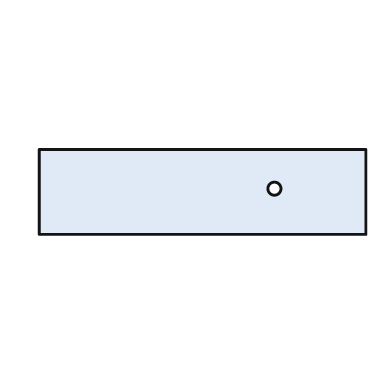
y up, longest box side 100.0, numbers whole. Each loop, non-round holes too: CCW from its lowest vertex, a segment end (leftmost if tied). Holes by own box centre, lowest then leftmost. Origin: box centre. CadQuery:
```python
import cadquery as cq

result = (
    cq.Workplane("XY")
    .moveTo(-50.0, -13.0)
    .lineTo(50.0, -13.0)
    .lineTo(50.0, 13.0)
    .lineTo(-50.0, 13.0)
    .close()
    .moveTo(22.0, 1.0)
    .circle(2.0)
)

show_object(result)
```